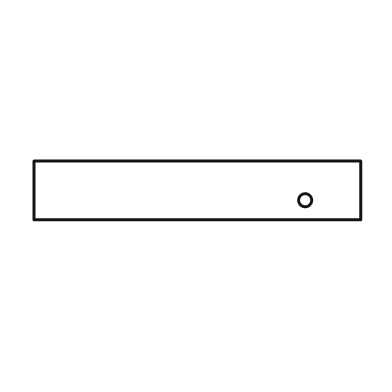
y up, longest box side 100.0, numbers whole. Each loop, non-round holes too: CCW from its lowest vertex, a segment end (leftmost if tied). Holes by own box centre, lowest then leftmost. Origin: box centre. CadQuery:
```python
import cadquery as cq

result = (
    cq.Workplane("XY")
    .moveTo(-50.0, -9.0)
    .lineTo(50.0, -9.0)
    .lineTo(50.0, 9.0)
    .lineTo(-50.0, 9.0)
    .close()
    .moveTo(33.0, -3.0)
    .circle(2.0)
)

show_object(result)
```